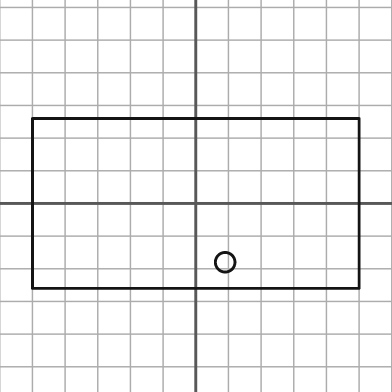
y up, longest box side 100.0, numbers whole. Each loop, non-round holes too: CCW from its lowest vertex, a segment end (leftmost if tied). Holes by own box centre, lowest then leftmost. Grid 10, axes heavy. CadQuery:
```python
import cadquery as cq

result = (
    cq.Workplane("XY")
    .moveTo(-50.0, -26.0)
    .lineTo(50.0, -26.0)
    .lineTo(50.0, 26.0)
    .lineTo(-50.0, 26.0)
    .close()
    .moveTo(9.0, -18.0)
    .circle(3.0)
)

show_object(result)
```